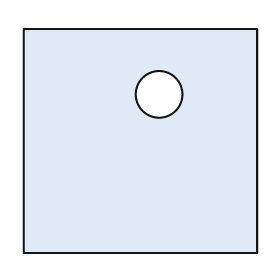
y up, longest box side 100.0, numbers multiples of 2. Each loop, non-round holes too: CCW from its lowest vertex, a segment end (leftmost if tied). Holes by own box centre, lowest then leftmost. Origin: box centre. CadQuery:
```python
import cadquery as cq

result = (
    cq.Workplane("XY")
    .moveTo(-50.0, -48.0)
    .lineTo(50.0, -48.0)
    .lineTo(50.0, 48.0)
    .lineTo(-50.0, 48.0)
    .close()
    .moveTo(8.0, 20.0)
    .circle(10.0)
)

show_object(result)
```